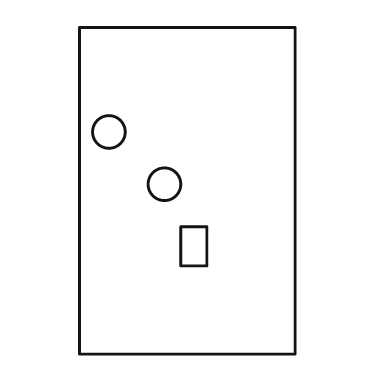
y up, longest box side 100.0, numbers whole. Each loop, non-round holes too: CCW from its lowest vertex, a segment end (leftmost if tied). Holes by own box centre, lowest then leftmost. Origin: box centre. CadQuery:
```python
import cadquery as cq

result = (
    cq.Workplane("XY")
    .moveTo(-33.0, -50.0)
    .lineTo(33.0, -50.0)
    .lineTo(33.0, 50.0)
    .lineTo(-33.0, 50.0)
    .close()
    .moveTo(-2.0, -23.0)
    .lineTo(6.0, -23.0)
    .lineTo(6.0, -11.0)
    .lineTo(-2.0, -11.0)
    .close()
    .moveTo(-7.0, 2.0)
    .circle(5.0)
    .moveTo(-24.0, 18.0)
    .circle(5.0)
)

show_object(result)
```